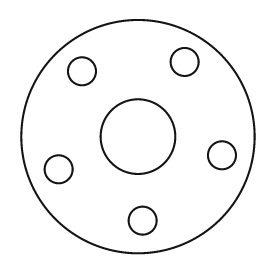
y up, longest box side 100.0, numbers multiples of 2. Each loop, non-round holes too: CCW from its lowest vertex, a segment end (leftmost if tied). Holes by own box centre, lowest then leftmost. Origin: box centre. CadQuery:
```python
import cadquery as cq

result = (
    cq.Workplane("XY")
    .moveTo(0.0, 0.0)
    .circle(50.0)
    .moveTo(2.0, -36.0)
    .circle(6.0)
    .moveTo(-34.0, -14.0)
    .circle(6.0)
    .moveTo(36.0, -8.0)
    .circle(6.0)
    .moveTo(0.0, 0.0)
    .circle(16.0)
    .moveTo(-24.0, 28.0)
    .circle(6.0)
    .moveTo(20.0, 32.0)
    .circle(6.0)
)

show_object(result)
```